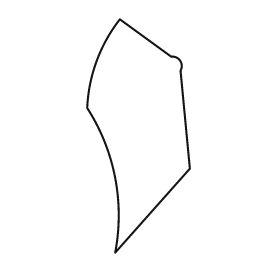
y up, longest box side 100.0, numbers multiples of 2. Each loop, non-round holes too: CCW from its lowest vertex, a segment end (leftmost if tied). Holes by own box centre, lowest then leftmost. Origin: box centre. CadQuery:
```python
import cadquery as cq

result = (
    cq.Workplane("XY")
    .moveTo(-10.0, -50.0)
    .lineTo(22.0, -14.0)
    .lineTo(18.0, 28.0)
    .threePointArc((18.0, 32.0), (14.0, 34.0))
    .lineTo(-8.0, 50.0)
    .threePointArc((-18.0, 32.0), (-22.0, 12.0))
    .threePointArc((-10.0, -18.0), (-10.0, -50.0))
    .close()
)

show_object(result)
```